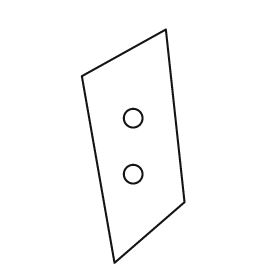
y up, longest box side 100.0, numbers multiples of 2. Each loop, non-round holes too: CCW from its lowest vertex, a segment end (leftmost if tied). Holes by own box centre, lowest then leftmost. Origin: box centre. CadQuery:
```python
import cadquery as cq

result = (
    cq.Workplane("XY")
    .moveTo(-8.0, -50.0)
    .lineTo(22.0, -24.0)
    .lineTo(14.0, 50.0)
    .lineTo(-22.0, 30.0)
    .close()
    .moveTo(0.0, -12.0)
    .circle(4.0)
    .moveTo(0.0, 12.0)
    .circle(4.0)
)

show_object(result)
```